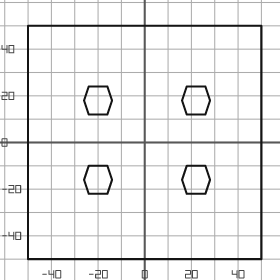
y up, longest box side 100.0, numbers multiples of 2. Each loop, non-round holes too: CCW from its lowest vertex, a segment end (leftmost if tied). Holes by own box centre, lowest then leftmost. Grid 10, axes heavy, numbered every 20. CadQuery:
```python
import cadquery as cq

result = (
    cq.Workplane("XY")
    .moveTo(-50.0, -50.0)
    .lineTo(50.0, -50.0)
    .lineTo(50.0, 50.0)
    .lineTo(-50.0, 50.0)
    .close()
    .moveTo(-24.0, -22.0)
    .lineTo(-16.0, -22.0)
    .lineTo(-14.0, -16.0)
    .lineTo(-16.0, -10.0)
    .lineTo(-24.0, -10.0)
    .lineTo(-26.0, -16.0)
    .close()
    .moveTo(18.0, -22.0)
    .lineTo(26.0, -22.0)
    .lineTo(28.0, -16.0)
    .lineTo(26.0, -10.0)
    .lineTo(18.0, -10.0)
    .lineTo(16.0, -16.0)
    .close()
    .moveTo(-24.0, 12.0)
    .lineTo(-16.0, 12.0)
    .lineTo(-14.0, 18.0)
    .lineTo(-16.0, 24.0)
    .lineTo(-24.0, 24.0)
    .lineTo(-26.0, 18.0)
    .close()
    .moveTo(18.0, 12.0)
    .lineTo(26.0, 12.0)
    .lineTo(28.0, 18.0)
    .lineTo(26.0, 24.0)
    .lineTo(18.0, 24.0)
    .lineTo(16.0, 18.0)
    .close()
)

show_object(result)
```